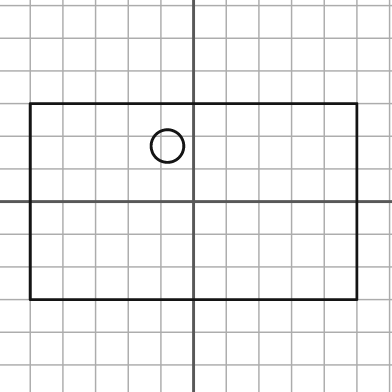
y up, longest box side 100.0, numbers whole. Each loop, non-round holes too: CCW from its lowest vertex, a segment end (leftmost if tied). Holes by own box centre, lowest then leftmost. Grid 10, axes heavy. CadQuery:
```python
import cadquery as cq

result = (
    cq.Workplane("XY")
    .moveTo(-50.0, -30.0)
    .lineTo(50.0, -30.0)
    .lineTo(50.0, 30.0)
    .lineTo(-50.0, 30.0)
    .close()
    .moveTo(-8.0, 17.0)
    .circle(5.0)
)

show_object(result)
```